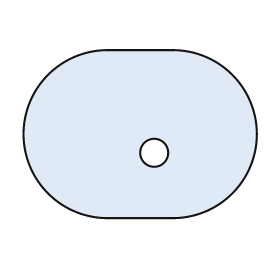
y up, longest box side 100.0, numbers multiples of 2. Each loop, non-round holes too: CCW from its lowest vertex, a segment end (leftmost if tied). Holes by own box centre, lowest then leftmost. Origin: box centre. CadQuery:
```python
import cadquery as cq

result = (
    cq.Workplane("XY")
    .moveTo(-14.0, -36.0)
    .lineTo(14.0, -36.0)
    .threePointArc((50.0, 0.0), (14.0, 36.0))
    .lineTo(-14.0, 36.0)
    .threePointArc((-50.0, 0.0), (-14.0, -36.0))
    .close()
    .moveTo(6.0, -8.0)
    .circle(6.0)
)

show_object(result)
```